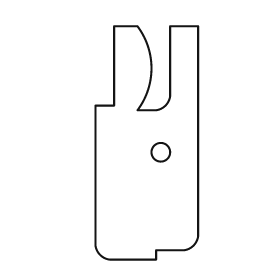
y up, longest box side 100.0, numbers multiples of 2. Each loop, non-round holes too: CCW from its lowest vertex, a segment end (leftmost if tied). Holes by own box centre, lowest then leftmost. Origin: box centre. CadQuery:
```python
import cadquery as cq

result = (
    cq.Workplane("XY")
    .moveTo(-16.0, -50.0)
    .lineTo(4.0, -50.0)
    .lineTo(4.0, -46.0)
    .lineTo(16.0, -46.0)
    .threePointArc((20.0, -44.0), (22.0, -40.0))
    .lineTo(22.0, 50.0)
    .lineTo(10.0, 50.0)
    .lineTo(10.0, 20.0)
    .threePointArc((8.0, 16.0), (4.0, 14.0))
    .lineTo(-4.0, 14.0)
    .threePointArc((2.0, 32.0), (-4.0, 50.0))
    .lineTo(-14.0, 50.0)
    .lineTo(-14.0, 16.0)
    .lineTo(-22.0, 16.0)
    .lineTo(-22.0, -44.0)
    .threePointArc((-20.0, -48.0), (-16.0, -50.0))
    .close()
    .moveTo(6.0, -4.0)
    .circle(4.0)
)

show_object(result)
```